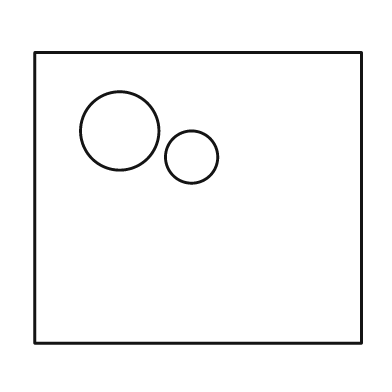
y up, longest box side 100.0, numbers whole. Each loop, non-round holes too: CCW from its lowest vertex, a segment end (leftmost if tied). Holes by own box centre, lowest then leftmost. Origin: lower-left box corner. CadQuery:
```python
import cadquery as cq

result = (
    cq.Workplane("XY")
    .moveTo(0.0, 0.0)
    .lineTo(100.0, 0.0)
    .lineTo(100.0, 89.0)
    .lineTo(0.0, 89.0)
    .close()
    .moveTo(48.0, 57.0)
    .circle(8.0)
    .moveTo(26.0, 65.0)
    .circle(12.0)
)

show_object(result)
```